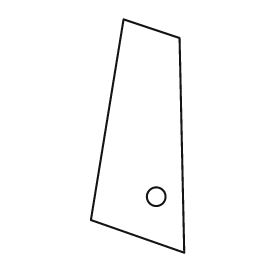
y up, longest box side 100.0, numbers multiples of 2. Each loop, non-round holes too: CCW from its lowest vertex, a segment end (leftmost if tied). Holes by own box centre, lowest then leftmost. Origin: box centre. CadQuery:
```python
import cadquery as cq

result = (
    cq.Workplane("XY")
    .moveTo(20.0, -50.0)
    .lineTo(18.0, 42.0)
    .lineTo(-6.0, 50.0)
    .lineTo(-20.0, -36.0)
    .close()
    .moveTo(8.0, -26.0)
    .circle(4.0)
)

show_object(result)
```